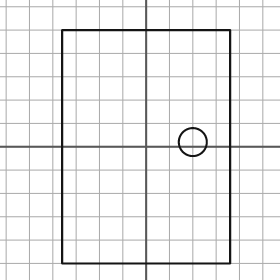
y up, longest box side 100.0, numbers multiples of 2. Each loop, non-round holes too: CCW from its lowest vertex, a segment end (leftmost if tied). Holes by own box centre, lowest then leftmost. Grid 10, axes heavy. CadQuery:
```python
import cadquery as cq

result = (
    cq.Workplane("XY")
    .moveTo(-36.0, -50.0)
    .lineTo(36.0, -50.0)
    .lineTo(36.0, 50.0)
    .lineTo(-36.0, 50.0)
    .close()
    .moveTo(20.0, 2.0)
    .circle(6.0)
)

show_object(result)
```